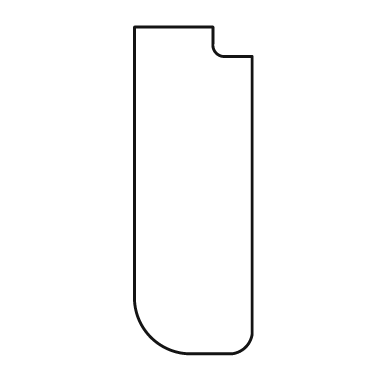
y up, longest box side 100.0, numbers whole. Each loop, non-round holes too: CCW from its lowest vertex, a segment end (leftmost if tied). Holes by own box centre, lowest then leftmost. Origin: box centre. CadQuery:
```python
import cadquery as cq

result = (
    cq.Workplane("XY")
    .moveTo(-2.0, -50.0)
    .lineTo(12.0, -50.0)
    .threePointArc((16.0, -48.0), (18.0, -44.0))
    .lineTo(18.0, 41.0)
    .lineTo(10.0, 41.0)
    .threePointArc((7.0, 42.0), (6.0, 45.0))
    .lineTo(6.0, 50.0)
    .lineTo(-18.0, 50.0)
    .lineTo(-18.0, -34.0)
    .threePointArc((-13.0, -45.0), (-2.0, -50.0))
    .close()
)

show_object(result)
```